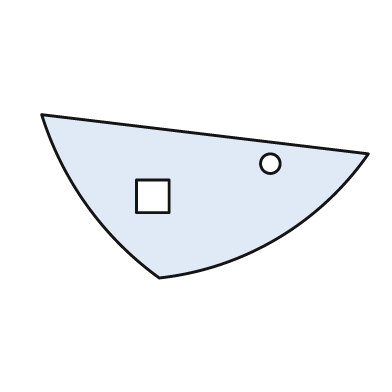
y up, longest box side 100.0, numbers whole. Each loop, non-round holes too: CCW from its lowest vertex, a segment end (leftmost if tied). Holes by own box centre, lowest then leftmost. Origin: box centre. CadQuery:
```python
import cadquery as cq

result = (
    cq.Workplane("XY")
    .moveTo(-14.0, -25.0)
    .threePointArc((22.0, -13.0), (50.0, 13.0))
    .lineTo(-50.0, 25.0)
    .threePointArc((-36.0, -3.0), (-14.0, -25.0))
    .close()
    .moveTo(-21.0, -5.0)
    .lineTo(-11.0, -5.0)
    .lineTo(-11.0, 5.0)
    .lineTo(-21.0, 5.0)
    .close()
    .moveTo(20.0, 10.0)
    .circle(3.0)
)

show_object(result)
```